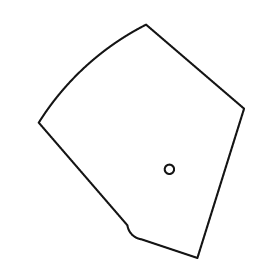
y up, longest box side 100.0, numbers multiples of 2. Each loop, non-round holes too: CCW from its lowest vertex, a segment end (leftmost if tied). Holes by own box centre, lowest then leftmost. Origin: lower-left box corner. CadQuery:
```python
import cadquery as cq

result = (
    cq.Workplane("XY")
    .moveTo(68.0, 0.0)
    .lineTo(88.0, 64.0)
    .lineTo(46.0, 100.0)
    .threePointArc((20.0, 82.0), (0.0, 58.0))
    .lineTo(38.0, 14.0)
    .threePointArc((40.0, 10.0), (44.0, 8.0))
    .close()
    .moveTo(56.0, 38.0)
    .circle(2.0)
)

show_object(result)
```